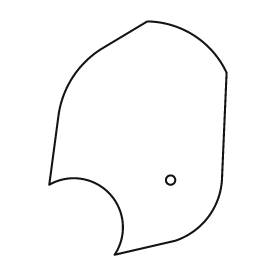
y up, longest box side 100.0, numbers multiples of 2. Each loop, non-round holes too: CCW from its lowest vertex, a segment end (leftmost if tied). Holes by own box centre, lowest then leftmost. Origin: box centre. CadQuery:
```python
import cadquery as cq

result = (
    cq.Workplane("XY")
    .moveTo(-10.0, -50.0)
    .lineTo(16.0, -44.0)
    .threePointArc((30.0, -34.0), (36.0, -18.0))
    .lineTo(38.0, 28.0)
    .threePointArc((24.0, 44.0), (4.0, 50.0))
    .lineTo(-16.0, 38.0)
    .threePointArc((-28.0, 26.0), (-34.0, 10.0))
    .lineTo(-38.0, -20.0)
    .threePointArc((-12.0, -24.0), (-10.0, -50.0))
    .close()
    .moveTo(14.0, -18.0)
    .circle(2.0)
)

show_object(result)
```